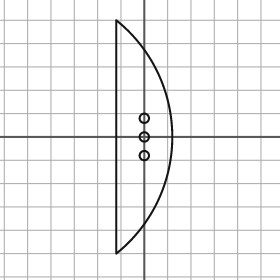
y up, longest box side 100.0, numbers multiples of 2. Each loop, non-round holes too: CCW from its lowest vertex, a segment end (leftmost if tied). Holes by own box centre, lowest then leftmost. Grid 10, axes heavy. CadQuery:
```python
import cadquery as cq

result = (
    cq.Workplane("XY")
    .moveTo(-12.0, -50.0)
    .threePointArc((12.0, 0.0), (-12.0, 50.0))
    .close()
    .moveTo(0.0, -8.0)
    .circle(2.0)
    .moveTo(0.0, 0.0)
    .circle(2.0)
    .moveTo(0.0, 8.0)
    .circle(2.0)
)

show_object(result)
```